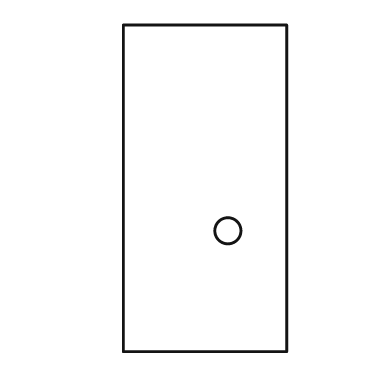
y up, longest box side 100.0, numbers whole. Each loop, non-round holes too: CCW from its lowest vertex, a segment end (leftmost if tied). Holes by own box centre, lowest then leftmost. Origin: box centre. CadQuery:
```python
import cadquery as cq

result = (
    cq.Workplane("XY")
    .moveTo(-25.0, -50.0)
    .lineTo(25.0, -50.0)
    .lineTo(25.0, 50.0)
    .lineTo(-25.0, 50.0)
    .close()
    .moveTo(7.0, -13.0)
    .circle(4.0)
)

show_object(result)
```